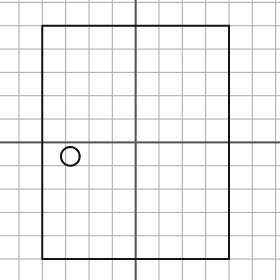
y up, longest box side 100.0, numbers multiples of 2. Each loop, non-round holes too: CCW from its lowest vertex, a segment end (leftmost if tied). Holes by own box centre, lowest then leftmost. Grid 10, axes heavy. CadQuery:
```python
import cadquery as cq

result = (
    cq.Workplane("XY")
    .moveTo(-40.0, -50.0)
    .lineTo(40.0, -50.0)
    .lineTo(40.0, 50.0)
    .lineTo(-40.0, 50.0)
    .close()
    .moveTo(-28.0, -6.0)
    .circle(4.0)
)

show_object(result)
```